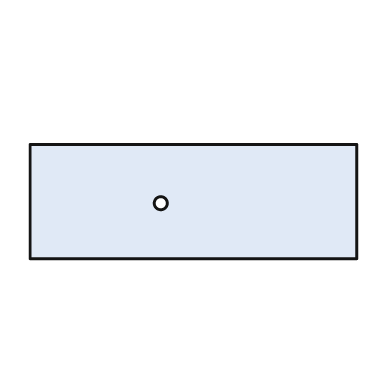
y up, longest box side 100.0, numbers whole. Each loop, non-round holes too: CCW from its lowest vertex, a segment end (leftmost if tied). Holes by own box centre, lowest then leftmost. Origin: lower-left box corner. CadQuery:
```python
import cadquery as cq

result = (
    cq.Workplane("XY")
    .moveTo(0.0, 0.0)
    .lineTo(100.0, 0.0)
    .lineTo(100.0, 35.0)
    .lineTo(0.0, 35.0)
    .close()
    .moveTo(40.0, 17.0)
    .circle(2.0)
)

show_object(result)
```